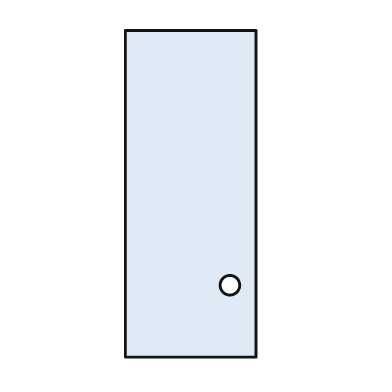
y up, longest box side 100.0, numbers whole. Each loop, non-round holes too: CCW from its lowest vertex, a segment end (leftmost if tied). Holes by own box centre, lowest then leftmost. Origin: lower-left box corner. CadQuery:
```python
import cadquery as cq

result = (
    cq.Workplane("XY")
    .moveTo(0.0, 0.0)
    .lineTo(40.0, 0.0)
    .lineTo(40.0, 100.0)
    .lineTo(0.0, 100.0)
    .close()
    .moveTo(32.0, 22.0)
    .circle(3.0)
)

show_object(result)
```